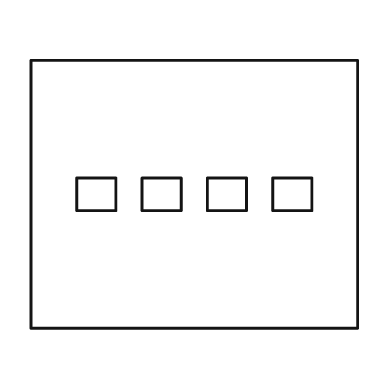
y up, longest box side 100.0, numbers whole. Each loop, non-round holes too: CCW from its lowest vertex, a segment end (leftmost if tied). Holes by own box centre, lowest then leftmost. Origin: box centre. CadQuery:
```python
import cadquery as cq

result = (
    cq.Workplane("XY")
    .moveTo(-50.0, -41.0)
    .lineTo(50.0, -41.0)
    .lineTo(50.0, 41.0)
    .lineTo(-50.0, 41.0)
    .close()
    .moveTo(-36.0, -5.0)
    .lineTo(-24.0, -5.0)
    .lineTo(-24.0, 5.0)
    .lineTo(-36.0, 5.0)
    .close()
    .moveTo(-16.0, -5.0)
    .lineTo(-4.0, -5.0)
    .lineTo(-4.0, 5.0)
    .lineTo(-16.0, 5.0)
    .close()
    .moveTo(4.0, -5.0)
    .lineTo(16.0, -5.0)
    .lineTo(16.0, 5.0)
    .lineTo(4.0, 5.0)
    .close()
    .moveTo(24.0, -5.0)
    .lineTo(36.0, -5.0)
    .lineTo(36.0, 5.0)
    .lineTo(24.0, 5.0)
    .close()
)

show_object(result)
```